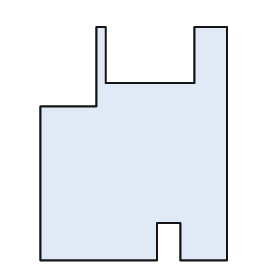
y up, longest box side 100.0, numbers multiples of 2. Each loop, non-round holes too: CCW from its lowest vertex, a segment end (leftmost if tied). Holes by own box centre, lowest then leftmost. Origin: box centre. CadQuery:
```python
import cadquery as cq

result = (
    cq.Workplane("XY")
    .moveTo(-40.0, -50.0)
    .lineTo(10.0, -50.0)
    .lineTo(10.0, -34.0)
    .lineTo(20.0, -34.0)
    .lineTo(20.0, -50.0)
    .lineTo(40.0, -50.0)
    .lineTo(40.0, 50.0)
    .lineTo(26.0, 50.0)
    .lineTo(26.0, 26.0)
    .lineTo(-12.0, 26.0)
    .lineTo(-12.0, 50.0)
    .lineTo(-16.0, 50.0)
    .lineTo(-16.0, 16.0)
    .lineTo(-40.0, 16.0)
    .close()
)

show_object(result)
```